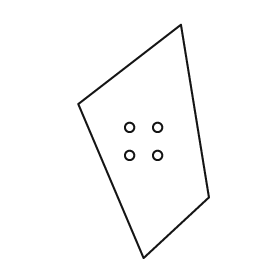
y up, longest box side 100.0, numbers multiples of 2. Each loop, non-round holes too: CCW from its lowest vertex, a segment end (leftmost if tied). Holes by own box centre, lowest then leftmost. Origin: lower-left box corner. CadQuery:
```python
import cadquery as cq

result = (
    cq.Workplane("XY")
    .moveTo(28.0, 0.0)
    .lineTo(56.0, 26.0)
    .lineTo(44.0, 100.0)
    .lineTo(0.0, 66.0)
    .close()
    .moveTo(22.0, 44.0)
    .circle(2.0)
    .moveTo(34.0, 44.0)
    .circle(2.0)
    .moveTo(22.0, 56.0)
    .circle(2.0)
    .moveTo(34.0, 56.0)
    .circle(2.0)
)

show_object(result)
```